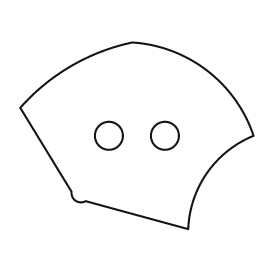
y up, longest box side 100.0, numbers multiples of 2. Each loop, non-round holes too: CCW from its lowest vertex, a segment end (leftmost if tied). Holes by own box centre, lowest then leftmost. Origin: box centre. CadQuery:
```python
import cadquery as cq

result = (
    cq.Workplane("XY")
    .moveTo(22.0, -40.0)
    .threePointArc((30.0, -16.0), (50.0, 0.0))
    .threePointArc((30.0, 28.0), (-2.0, 40.0))
    .threePointArc((-28.0, 30.0), (-50.0, 12.0))
    .lineTo(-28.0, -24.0)
    .threePointArc((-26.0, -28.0), (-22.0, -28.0))
    .close()
    .moveTo(-12.0, 0.0)
    .circle(6.0)
    .moveTo(12.0, 0.0)
    .circle(6.0)
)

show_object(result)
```